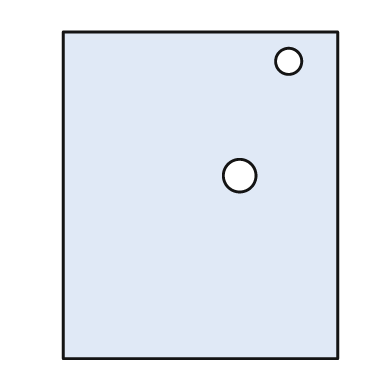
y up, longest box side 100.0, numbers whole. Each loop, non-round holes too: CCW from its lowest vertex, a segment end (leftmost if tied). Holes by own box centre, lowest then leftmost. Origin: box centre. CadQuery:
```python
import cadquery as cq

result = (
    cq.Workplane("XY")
    .moveTo(-42.0, -50.0)
    .lineTo(42.0, -50.0)
    .lineTo(42.0, 50.0)
    .lineTo(-42.0, 50.0)
    .close()
    .moveTo(12.0, 6.0)
    .circle(5.0)
    .moveTo(27.0, 41.0)
    .circle(4.0)
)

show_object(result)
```